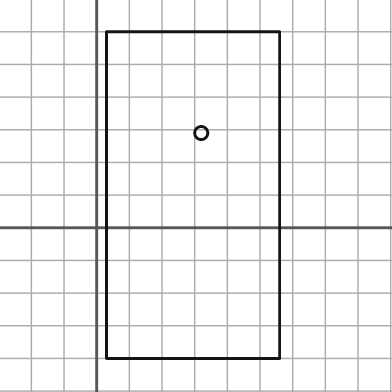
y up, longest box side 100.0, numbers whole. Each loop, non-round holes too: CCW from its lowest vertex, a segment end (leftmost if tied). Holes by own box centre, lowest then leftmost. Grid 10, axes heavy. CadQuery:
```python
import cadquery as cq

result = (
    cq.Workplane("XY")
    .moveTo(3.0, -40.0)
    .lineTo(56.0, -40.0)
    .lineTo(56.0, 60.0)
    .lineTo(3.0, 60.0)
    .close()
    .moveTo(32.0, 29.0)
    .circle(2.0)
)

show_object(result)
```